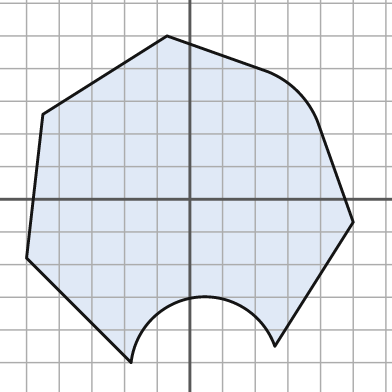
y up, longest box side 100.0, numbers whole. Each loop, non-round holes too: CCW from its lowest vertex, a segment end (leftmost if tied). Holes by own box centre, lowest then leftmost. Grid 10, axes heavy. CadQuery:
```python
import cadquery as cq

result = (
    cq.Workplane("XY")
    .moveTo(-18.0, -50.0)
    .threePointArc((2.0, -30.0), (26.0, -45.0))
    .lineTo(50.0, -7.0)
    .lineTo(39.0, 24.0)
    .threePointArc((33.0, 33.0), (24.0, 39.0))
    .lineTo(-7.0, 50.0)
    .lineTo(-45.0, 26.0)
    .lineTo(-50.0, -18.0)
    .close()
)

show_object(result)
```